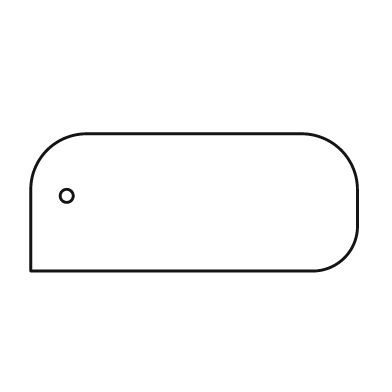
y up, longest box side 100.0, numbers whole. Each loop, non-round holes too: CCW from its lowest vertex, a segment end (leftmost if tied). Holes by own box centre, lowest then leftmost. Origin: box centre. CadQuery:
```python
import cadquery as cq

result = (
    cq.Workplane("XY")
    .moveTo(-50.0, -21.0)
    .lineTo(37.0, -21.0)
    .threePointArc((46.0, -17.0), (50.0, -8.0))
    .lineTo(50.0, 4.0)
    .threePointArc((45.0, 16.0), (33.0, 21.0))
    .lineTo(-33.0, 21.0)
    .threePointArc((-45.0, 16.0), (-50.0, 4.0))
    .close()
    .moveTo(-39.0, 2.0)
    .circle(2.0)
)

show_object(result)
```